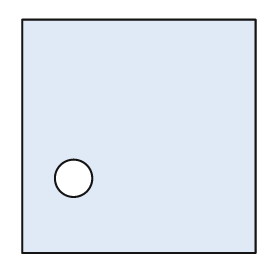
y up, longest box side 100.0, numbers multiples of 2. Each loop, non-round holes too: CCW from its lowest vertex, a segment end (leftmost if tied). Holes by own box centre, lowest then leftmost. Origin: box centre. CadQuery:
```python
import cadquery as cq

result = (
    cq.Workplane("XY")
    .moveTo(-50.0, -50.0)
    .lineTo(50.0, -50.0)
    .lineTo(50.0, 50.0)
    .lineTo(-50.0, 50.0)
    .close()
    .moveTo(-28.0, -18.0)
    .circle(8.0)
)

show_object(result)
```